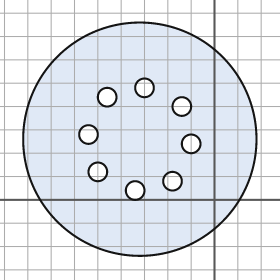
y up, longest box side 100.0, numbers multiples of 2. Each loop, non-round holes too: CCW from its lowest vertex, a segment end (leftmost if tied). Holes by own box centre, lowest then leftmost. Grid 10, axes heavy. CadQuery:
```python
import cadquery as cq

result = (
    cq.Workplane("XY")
    .moveTo(-32.0, 26.0)
    .circle(50.0)
    .moveTo(-34.0, 4.0)
    .circle(4.0)
    .moveTo(-18.0, 8.0)
    .circle(4.0)
    .moveTo(-50.0, 12.0)
    .circle(4.0)
    .moveTo(-10.0, 24.0)
    .circle(4.0)
    .moveTo(-54.0, 28.0)
    .circle(4.0)
    .moveTo(-14.0, 40.0)
    .circle(4.0)
    .moveTo(-46.0, 44.0)
    .circle(4.0)
    .moveTo(-30.0, 48.0)
    .circle(4.0)
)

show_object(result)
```